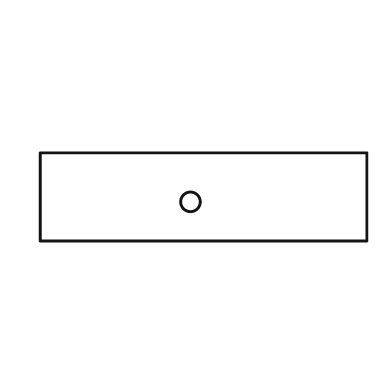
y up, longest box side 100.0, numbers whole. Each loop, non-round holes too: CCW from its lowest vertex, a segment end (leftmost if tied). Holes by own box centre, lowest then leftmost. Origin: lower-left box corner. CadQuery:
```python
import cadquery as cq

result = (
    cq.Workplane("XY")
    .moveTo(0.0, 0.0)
    .lineTo(100.0, 0.0)
    .lineTo(100.0, 27.0)
    .lineTo(0.0, 27.0)
    .close()
    .moveTo(46.0, 12.0)
    .circle(3.0)
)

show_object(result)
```